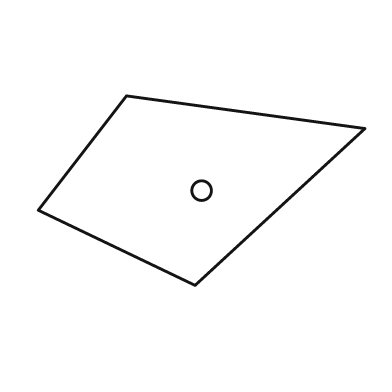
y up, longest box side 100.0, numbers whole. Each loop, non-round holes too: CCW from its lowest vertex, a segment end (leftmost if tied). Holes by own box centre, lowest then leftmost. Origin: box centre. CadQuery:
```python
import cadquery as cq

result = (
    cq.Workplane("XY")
    .moveTo(-2.0, -29.0)
    .lineTo(50.0, 19.0)
    .lineTo(-23.0, 29.0)
    .lineTo(-50.0, -6.0)
    .close()
    .moveTo(0.0, 0.0)
    .circle(3.0)
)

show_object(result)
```